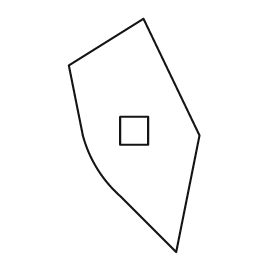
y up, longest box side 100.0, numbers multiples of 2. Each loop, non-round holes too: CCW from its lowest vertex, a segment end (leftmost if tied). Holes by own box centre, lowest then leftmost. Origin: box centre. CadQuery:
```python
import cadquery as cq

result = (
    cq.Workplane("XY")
    .moveTo(18.0, -50.0)
    .lineTo(28.0, 0.0)
    .lineTo(4.0, 50.0)
    .lineTo(-28.0, 30.0)
    .lineTo(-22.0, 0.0)
    .threePointArc((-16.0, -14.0), (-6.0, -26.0))
    .close()
    .moveTo(-6.0, -4.0)
    .lineTo(6.0, -4.0)
    .lineTo(6.0, 8.0)
    .lineTo(-6.0, 8.0)
    .close()
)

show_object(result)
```